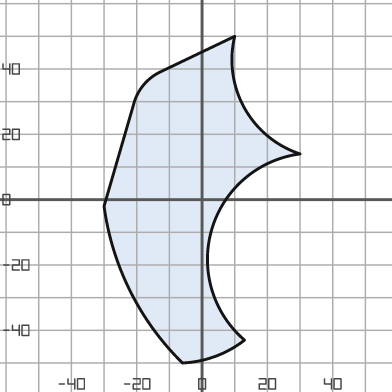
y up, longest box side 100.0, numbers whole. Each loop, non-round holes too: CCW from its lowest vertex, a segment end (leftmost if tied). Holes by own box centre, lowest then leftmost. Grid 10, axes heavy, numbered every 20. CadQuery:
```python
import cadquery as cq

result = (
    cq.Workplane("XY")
    .moveTo(-6.0, -50.0)
    .threePointArc((4.0, -48.0), (13.0, -43.0))
    .threePointArc((3.0, -9.0), (30.0, 14.0))
    .threePointArc((13.0, 28.0), (10.0, 50.0))
    .lineTo(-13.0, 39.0)
    .threePointArc((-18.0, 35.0), (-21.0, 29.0))
    .lineTo(-30.0, -2.0)
    .threePointArc((-22.0, -28.0), (-6.0, -50.0))
    .close()
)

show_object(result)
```